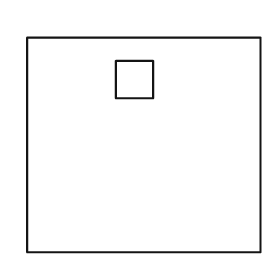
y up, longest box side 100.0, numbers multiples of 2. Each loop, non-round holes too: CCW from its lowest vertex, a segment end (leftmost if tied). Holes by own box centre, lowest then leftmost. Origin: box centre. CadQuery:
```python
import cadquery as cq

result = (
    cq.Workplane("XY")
    .moveTo(-50.0, -46.0)
    .lineTo(50.0, -46.0)
    .lineTo(50.0, 46.0)
    .lineTo(-50.0, 46.0)
    .close()
    .moveTo(-12.0, 20.0)
    .lineTo(4.0, 20.0)
    .lineTo(4.0, 36.0)
    .lineTo(-12.0, 36.0)
    .close()
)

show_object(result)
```